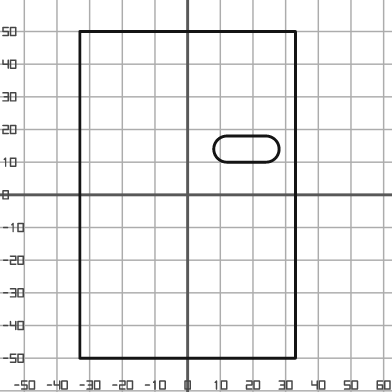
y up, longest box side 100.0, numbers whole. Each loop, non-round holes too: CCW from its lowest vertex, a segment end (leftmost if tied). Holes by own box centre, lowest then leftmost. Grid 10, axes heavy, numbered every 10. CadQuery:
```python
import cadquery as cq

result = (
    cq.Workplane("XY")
    .moveTo(-33.0, -50.0)
    .lineTo(33.0, -50.0)
    .lineTo(33.0, 50.0)
    .lineTo(-33.0, 50.0)
    .close()
    .moveTo(12.0, 10.0)
    .lineTo(24.0, 10.0)
    .threePointArc((28.0, 14.0), (24.0, 18.0))
    .lineTo(12.0, 18.0)
    .threePointArc((8.0, 14.0), (12.0, 10.0))
    .close()
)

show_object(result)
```